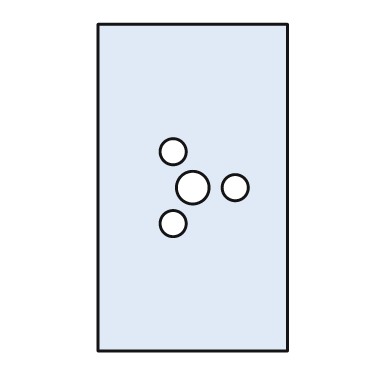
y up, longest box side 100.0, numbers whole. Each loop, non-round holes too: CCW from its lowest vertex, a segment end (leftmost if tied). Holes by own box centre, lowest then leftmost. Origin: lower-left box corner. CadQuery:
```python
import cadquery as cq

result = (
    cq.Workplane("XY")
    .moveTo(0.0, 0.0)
    .lineTo(58.0, 0.0)
    .lineTo(58.0, 100.0)
    .lineTo(0.0, 100.0)
    .close()
    .moveTo(23.0, 39.0)
    .circle(4.0)
    .moveTo(29.0, 50.0)
    .circle(5.0)
    .moveTo(42.0, 50.0)
    .circle(4.0)
    .moveTo(23.0, 61.0)
    .circle(4.0)
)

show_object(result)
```